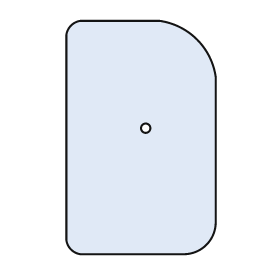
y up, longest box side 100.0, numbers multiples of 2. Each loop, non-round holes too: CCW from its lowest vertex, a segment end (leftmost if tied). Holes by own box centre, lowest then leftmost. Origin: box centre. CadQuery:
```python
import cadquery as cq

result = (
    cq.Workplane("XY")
    .moveTo(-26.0, -50.0)
    .lineTo(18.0, -50.0)
    .threePointArc((28.0, -46.0), (32.0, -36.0))
    .lineTo(32.0, 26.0)
    .threePointArc((24.0, 42.0), (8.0, 50.0))
    .lineTo(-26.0, 50.0)
    .threePointArc((-30.0, 48.0), (-32.0, 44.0))
    .lineTo(-32.0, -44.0)
    .threePointArc((-30.0, -48.0), (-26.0, -50.0))
    .close()
    .moveTo(2.0, 4.0)
    .circle(2.0)
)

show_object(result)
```